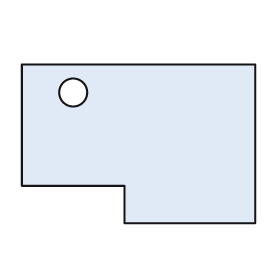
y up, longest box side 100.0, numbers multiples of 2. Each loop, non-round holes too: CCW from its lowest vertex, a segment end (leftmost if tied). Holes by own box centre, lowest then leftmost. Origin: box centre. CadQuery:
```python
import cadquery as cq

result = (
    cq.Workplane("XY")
    .moveTo(-6.0, -34.0)
    .lineTo(50.0, -34.0)
    .lineTo(50.0, 34.0)
    .lineTo(-50.0, 34.0)
    .lineTo(-50.0, -18.0)
    .lineTo(-6.0, -18.0)
    .close()
    .moveTo(-28.0, 22.0)
    .circle(6.0)
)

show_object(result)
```